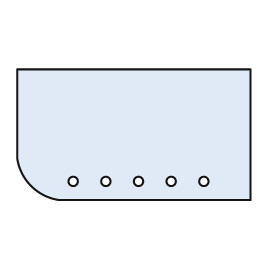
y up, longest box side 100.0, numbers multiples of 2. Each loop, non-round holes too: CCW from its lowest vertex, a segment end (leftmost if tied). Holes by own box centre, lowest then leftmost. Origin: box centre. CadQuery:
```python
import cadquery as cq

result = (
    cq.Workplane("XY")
    .moveTo(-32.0, -28.0)
    .lineTo(50.0, -28.0)
    .lineTo(50.0, 28.0)
    .lineTo(-50.0, 28.0)
    .lineTo(-50.0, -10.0)
    .threePointArc((-44.0, -22.0), (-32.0, -28.0))
    .close()
    .moveTo(-26.0, -20.0)
    .circle(2.0)
    .moveTo(-12.0, -20.0)
    .circle(2.0)
    .moveTo(2.0, -20.0)
    .circle(2.0)
    .moveTo(16.0, -20.0)
    .circle(2.0)
    .moveTo(30.0, -20.0)
    .circle(2.0)
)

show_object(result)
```